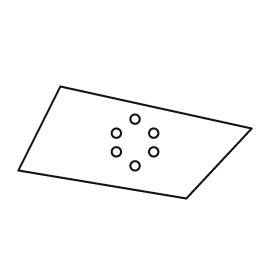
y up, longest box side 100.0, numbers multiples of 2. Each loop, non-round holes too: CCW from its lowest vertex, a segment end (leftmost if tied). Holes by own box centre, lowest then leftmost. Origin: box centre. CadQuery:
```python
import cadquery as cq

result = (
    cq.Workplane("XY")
    .moveTo(22.0, -24.0)
    .lineTo(50.0, 6.0)
    .lineTo(-32.0, 24.0)
    .lineTo(-50.0, -12.0)
    .close()
    .moveTo(0.0, -10.0)
    .circle(2.0)
    .moveTo(-8.0, -4.0)
    .circle(2.0)
    .moveTo(8.0, -4.0)
    .circle(2.0)
    .moveTo(-8.0, 4.0)
    .circle(2.0)
    .moveTo(8.0, 4.0)
    .circle(2.0)
    .moveTo(0.0, 10.0)
    .circle(2.0)
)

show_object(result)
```